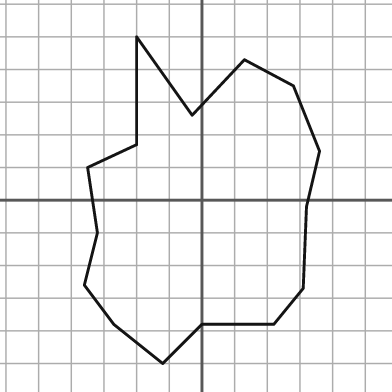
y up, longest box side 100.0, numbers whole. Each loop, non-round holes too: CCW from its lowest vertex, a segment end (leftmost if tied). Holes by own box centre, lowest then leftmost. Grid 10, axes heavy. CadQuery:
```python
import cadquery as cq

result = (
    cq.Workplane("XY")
    .moveTo(-12.0, -50.0)
    .lineTo(0.0, -38.0)
    .lineTo(22.0, -38.0)
    .lineTo(31.0, -27.0)
    .lineTo(32.0, -2.0)
    .lineTo(36.0, 15.0)
    .lineTo(28.0, 35.0)
    .lineTo(13.0, 43.0)
    .lineTo(-3.0, 26.0)
    .lineTo(-20.0, 50.0)
    .lineTo(-20.0, 17.0)
    .lineTo(-35.0, 10.0)
    .lineTo(-32.0, -10.0)
    .lineTo(-36.0, -26.0)
    .lineTo(-27.0, -38.0)
    .close()
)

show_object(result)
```